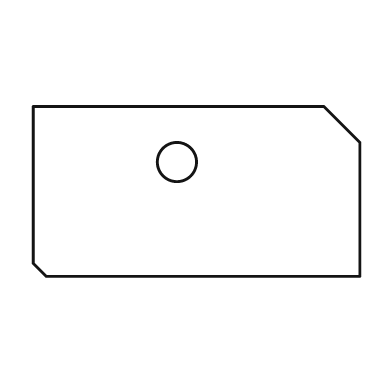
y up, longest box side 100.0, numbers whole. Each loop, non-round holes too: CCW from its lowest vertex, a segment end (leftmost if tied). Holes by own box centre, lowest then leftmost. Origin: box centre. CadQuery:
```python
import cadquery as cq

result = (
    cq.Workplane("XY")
    .moveTo(-46.0, -26.0)
    .lineTo(50.0, -26.0)
    .lineTo(50.0, 15.0)
    .lineTo(39.0, 26.0)
    .lineTo(-50.0, 26.0)
    .lineTo(-50.0, -22.0)
    .close()
    .moveTo(-6.0, 9.0)
    .circle(6.0)
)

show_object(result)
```